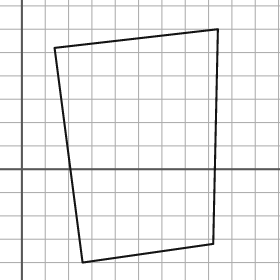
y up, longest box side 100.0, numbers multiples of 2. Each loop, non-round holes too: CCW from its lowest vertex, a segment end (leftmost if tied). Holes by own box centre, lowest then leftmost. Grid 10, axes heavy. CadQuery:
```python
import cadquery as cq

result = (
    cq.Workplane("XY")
    .moveTo(26.0, -40.0)
    .lineTo(82.0, -32.0)
    .lineTo(84.0, 60.0)
    .lineTo(14.0, 52.0)
    .close()
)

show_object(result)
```